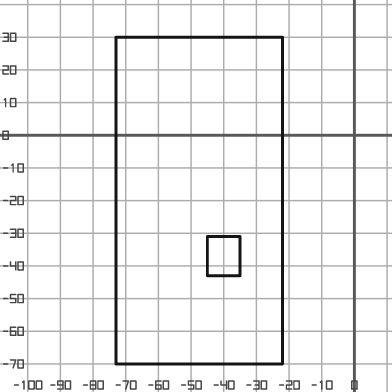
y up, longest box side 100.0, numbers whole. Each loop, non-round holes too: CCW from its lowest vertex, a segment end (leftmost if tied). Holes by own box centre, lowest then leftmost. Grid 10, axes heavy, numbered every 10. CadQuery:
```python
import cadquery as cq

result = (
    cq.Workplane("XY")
    .moveTo(-73.0, -70.0)
    .lineTo(-22.0, -70.0)
    .lineTo(-22.0, 30.0)
    .lineTo(-73.0, 30.0)
    .close()
    .moveTo(-45.0, -43.0)
    .lineTo(-35.0, -43.0)
    .lineTo(-35.0, -31.0)
    .lineTo(-45.0, -31.0)
    .close()
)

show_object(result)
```